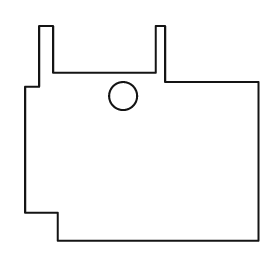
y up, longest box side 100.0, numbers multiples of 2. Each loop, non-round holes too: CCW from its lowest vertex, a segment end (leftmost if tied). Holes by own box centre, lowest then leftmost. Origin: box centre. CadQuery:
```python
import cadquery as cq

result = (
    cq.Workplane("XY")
    .moveTo(-36.0, -46.0)
    .lineTo(50.0, -46.0)
    .lineTo(50.0, 22.0)
    .lineTo(10.0, 22.0)
    .lineTo(10.0, 46.0)
    .lineTo(6.0, 46.0)
    .lineTo(6.0, 26.0)
    .lineTo(-38.0, 26.0)
    .lineTo(-38.0, 46.0)
    .lineTo(-44.0, 46.0)
    .lineTo(-44.0, 20.0)
    .lineTo(-50.0, 20.0)
    .lineTo(-50.0, -34.0)
    .lineTo(-36.0, -34.0)
    .close()
    .moveTo(-8.0, 16.0)
    .circle(6.0)
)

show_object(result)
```